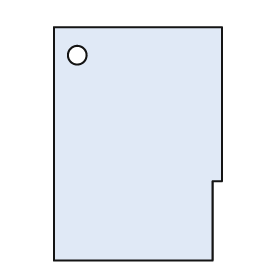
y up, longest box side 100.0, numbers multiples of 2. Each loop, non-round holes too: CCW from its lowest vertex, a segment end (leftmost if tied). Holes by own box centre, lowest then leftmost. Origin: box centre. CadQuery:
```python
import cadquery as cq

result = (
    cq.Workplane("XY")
    .moveTo(-36.0, -50.0)
    .lineTo(32.0, -50.0)
    .lineTo(32.0, -16.0)
    .lineTo(36.0, -16.0)
    .lineTo(36.0, 50.0)
    .lineTo(-36.0, 50.0)
    .close()
    .moveTo(-26.0, 38.0)
    .circle(4.0)
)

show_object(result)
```